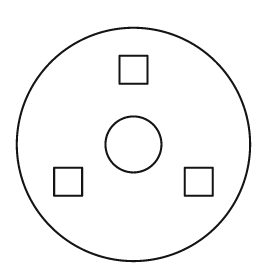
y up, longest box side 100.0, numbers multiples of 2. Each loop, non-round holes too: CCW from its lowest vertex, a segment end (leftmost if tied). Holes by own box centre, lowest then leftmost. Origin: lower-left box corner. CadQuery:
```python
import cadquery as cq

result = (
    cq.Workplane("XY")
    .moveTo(50.0, 50.0)
    .circle(50.0)
    .moveTo(16.0, 28.0)
    .lineTo(28.0, 28.0)
    .lineTo(28.0, 40.0)
    .lineTo(16.0, 40.0)
    .close()
    .moveTo(72.0, 28.0)
    .lineTo(84.0, 28.0)
    .lineTo(84.0, 40.0)
    .lineTo(72.0, 40.0)
    .close()
    .moveTo(50.0, 50.0)
    .circle(12.0)
    .moveTo(44.0, 76.0)
    .lineTo(56.0, 76.0)
    .lineTo(56.0, 88.0)
    .lineTo(44.0, 88.0)
    .close()
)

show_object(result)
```